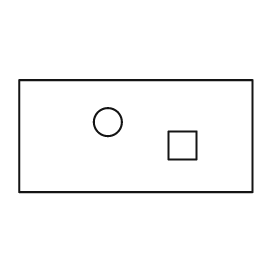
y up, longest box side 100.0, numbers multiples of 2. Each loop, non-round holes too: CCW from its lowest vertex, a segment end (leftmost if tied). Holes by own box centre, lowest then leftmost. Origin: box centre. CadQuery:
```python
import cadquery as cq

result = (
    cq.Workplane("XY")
    .moveTo(-50.0, -24.0)
    .lineTo(50.0, -24.0)
    .lineTo(50.0, 24.0)
    .lineTo(-50.0, 24.0)
    .close()
    .moveTo(14.0, -10.0)
    .lineTo(26.0, -10.0)
    .lineTo(26.0, 2.0)
    .lineTo(14.0, 2.0)
    .close()
    .moveTo(-12.0, 6.0)
    .circle(6.0)
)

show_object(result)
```